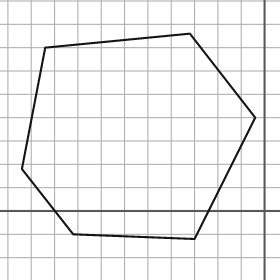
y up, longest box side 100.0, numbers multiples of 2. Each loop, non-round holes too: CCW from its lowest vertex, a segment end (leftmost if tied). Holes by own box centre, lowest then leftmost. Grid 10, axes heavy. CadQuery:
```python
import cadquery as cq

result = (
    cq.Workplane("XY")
    .moveTo(-30.0, -12.0)
    .lineTo(-4.0, 40.0)
    .lineTo(-32.0, 76.0)
    .lineTo(-94.0, 70.0)
    .lineTo(-104.0, 18.0)
    .lineTo(-82.0, -10.0)
    .close()
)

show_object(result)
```